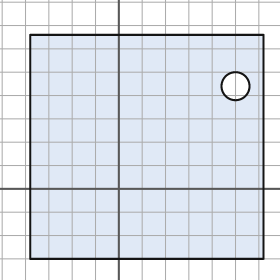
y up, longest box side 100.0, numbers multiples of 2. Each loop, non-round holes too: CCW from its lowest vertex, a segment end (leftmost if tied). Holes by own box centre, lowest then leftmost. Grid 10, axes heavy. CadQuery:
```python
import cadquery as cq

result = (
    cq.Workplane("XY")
    .moveTo(-38.0, -30.0)
    .lineTo(62.0, -30.0)
    .lineTo(62.0, 66.0)
    .lineTo(-38.0, 66.0)
    .close()
    .moveTo(50.0, 44.0)
    .circle(6.0)
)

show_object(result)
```